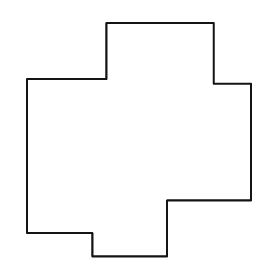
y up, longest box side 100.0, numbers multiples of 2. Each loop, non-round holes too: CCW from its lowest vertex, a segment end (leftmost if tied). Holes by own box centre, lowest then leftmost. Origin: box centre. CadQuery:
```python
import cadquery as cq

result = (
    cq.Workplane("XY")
    .moveTo(-20.0, -50.0)
    .lineTo(12.0, -50.0)
    .lineTo(12.0, -26.0)
    .lineTo(48.0, -26.0)
    .lineTo(48.0, 24.0)
    .lineTo(32.0, 24.0)
    .lineTo(32.0, 50.0)
    .lineTo(-14.0, 50.0)
    .lineTo(-14.0, 26.0)
    .lineTo(-48.0, 26.0)
    .lineTo(-48.0, -40.0)
    .lineTo(-20.0, -40.0)
    .close()
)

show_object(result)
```